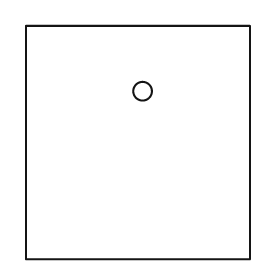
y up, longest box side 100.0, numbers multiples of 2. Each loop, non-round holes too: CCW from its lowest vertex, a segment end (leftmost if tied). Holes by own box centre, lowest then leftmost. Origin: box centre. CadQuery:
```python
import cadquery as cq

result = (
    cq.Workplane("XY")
    .moveTo(-48.0, -50.0)
    .lineTo(48.0, -50.0)
    .lineTo(48.0, 50.0)
    .lineTo(-48.0, 50.0)
    .close()
    .moveTo(2.0, 22.0)
    .circle(4.0)
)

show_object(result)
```